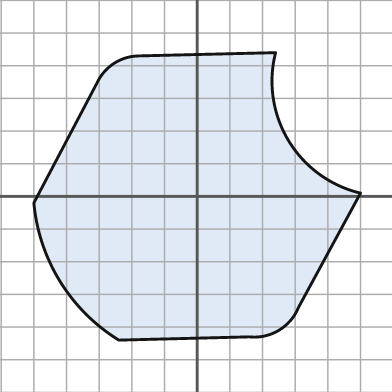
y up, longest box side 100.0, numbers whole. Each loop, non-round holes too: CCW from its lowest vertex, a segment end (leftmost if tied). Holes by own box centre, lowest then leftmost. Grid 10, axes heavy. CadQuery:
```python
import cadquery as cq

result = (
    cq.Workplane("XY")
    .moveTo(-24.0, -44.0)
    .lineTo(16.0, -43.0)
    .threePointArc((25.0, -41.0), (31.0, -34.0))
    .lineTo(50.0, 1.0)
    .threePointArc((28.0, 17.0), (24.0, 44.0))
    .lineTo(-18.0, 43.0)
    .threePointArc((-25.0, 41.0), (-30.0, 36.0))
    .lineTo(-50.0, -2.0)
    .threePointArc((-42.0, -26.0), (-24.0, -44.0))
    .close()
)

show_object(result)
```